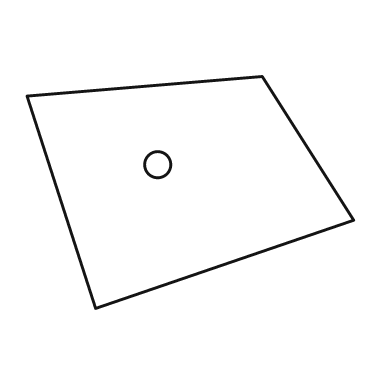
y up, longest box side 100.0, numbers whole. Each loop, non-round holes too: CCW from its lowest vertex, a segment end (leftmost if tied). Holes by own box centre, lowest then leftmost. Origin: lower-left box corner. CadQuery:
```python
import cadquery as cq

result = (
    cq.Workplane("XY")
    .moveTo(21.0, 0.0)
    .lineTo(100.0, 27.0)
    .lineTo(72.0, 71.0)
    .lineTo(0.0, 65.0)
    .close()
    .moveTo(40.0, 44.0)
    .circle(4.0)
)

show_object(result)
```